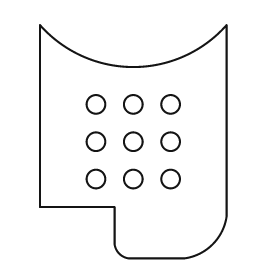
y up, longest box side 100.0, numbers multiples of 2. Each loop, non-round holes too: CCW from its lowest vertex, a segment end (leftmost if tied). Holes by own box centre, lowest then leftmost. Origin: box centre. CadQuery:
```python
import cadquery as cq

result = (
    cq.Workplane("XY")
    .moveTo(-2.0, -50.0)
    .lineTo(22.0, -50.0)
    .threePointArc((34.0, -44.0), (40.0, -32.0))
    .lineTo(40.0, 50.0)
    .threePointArc((0.0, 32.0), (-40.0, 50.0))
    .lineTo(-40.0, -28.0)
    .lineTo(-8.0, -28.0)
    .lineTo(-8.0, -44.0)
    .threePointArc((-6.0, -48.0), (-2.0, -50.0))
    .close()
    .moveTo(-16.0, -16.0)
    .circle(4.0)
    .moveTo(0.0, -16.0)
    .circle(4.0)
    .moveTo(16.0, -16.0)
    .circle(4.0)
    .moveTo(-16.0, 0.0)
    .circle(4.0)
    .moveTo(0.0, 0.0)
    .circle(4.0)
    .moveTo(16.0, 0.0)
    .circle(4.0)
    .moveTo(-16.0, 16.0)
    .circle(4.0)
    .moveTo(0.0, 16.0)
    .circle(4.0)
    .moveTo(16.0, 16.0)
    .circle(4.0)
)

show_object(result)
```